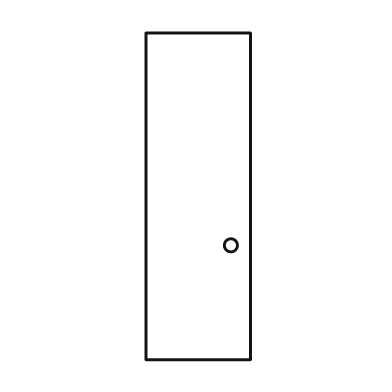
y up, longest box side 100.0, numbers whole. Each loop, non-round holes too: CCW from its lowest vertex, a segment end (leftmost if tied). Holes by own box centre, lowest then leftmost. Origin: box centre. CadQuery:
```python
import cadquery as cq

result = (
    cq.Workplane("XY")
    .moveTo(-16.0, -50.0)
    .lineTo(16.0, -50.0)
    .lineTo(16.0, 50.0)
    .lineTo(-16.0, 50.0)
    .close()
    .moveTo(10.0, -15.0)
    .circle(2.0)
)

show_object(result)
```